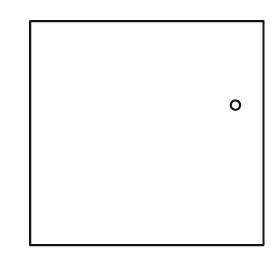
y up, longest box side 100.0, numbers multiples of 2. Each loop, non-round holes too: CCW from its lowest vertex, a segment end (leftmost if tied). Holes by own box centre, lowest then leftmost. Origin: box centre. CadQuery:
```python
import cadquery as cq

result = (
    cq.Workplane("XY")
    .moveTo(-50.0, -48.0)
    .lineTo(50.0, -48.0)
    .lineTo(50.0, 48.0)
    .lineTo(-50.0, 48.0)
    .close()
    .moveTo(38.0, 12.0)
    .circle(2.0)
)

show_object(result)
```